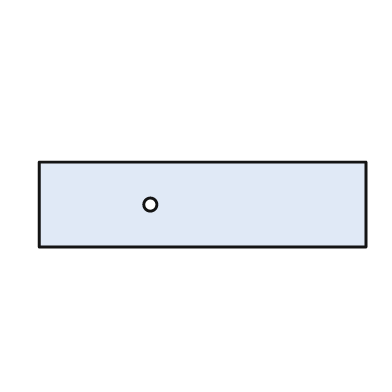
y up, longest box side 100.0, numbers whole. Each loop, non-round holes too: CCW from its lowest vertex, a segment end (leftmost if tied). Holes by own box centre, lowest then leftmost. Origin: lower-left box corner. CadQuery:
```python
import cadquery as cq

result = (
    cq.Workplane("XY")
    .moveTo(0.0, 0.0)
    .lineTo(100.0, 0.0)
    .lineTo(100.0, 26.0)
    .lineTo(0.0, 26.0)
    .close()
    .moveTo(34.0, 13.0)
    .circle(2.0)
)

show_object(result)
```